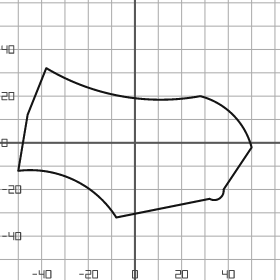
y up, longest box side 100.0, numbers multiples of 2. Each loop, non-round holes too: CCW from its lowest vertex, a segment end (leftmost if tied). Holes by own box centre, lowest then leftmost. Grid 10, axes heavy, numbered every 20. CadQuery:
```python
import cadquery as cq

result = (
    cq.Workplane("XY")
    .moveTo(-8.0, -32.0)
    .lineTo(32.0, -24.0)
    .threePointArc((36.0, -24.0), (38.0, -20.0))
    .lineTo(50.0, -2.0)
    .threePointArc((42.0, 12.0), (28.0, 20.0))
    .threePointArc((-6.0, 20.0), (-38.0, 32.0))
    .lineTo(-46.0, 12.0)
    .lineTo(-50.0, -12.0)
    .threePointArc((-26.0, -16.0), (-8.0, -32.0))
    .close()
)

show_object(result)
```